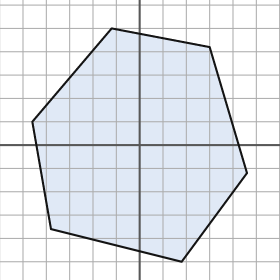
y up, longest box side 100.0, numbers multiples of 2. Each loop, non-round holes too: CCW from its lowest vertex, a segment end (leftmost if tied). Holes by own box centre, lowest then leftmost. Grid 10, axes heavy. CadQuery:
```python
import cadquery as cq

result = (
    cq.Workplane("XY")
    .moveTo(18.0, -50.0)
    .lineTo(46.0, -12.0)
    .lineTo(30.0, 42.0)
    .lineTo(-12.0, 50.0)
    .lineTo(-46.0, 10.0)
    .lineTo(-38.0, -36.0)
    .close()
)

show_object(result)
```